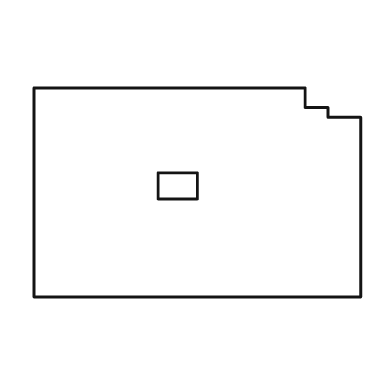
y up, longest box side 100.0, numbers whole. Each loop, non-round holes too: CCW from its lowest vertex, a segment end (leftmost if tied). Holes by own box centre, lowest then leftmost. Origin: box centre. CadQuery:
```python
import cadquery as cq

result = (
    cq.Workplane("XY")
    .moveTo(-50.0, -32.0)
    .lineTo(50.0, -32.0)
    .lineTo(50.0, 23.0)
    .lineTo(40.0, 23.0)
    .lineTo(40.0, 26.0)
    .lineTo(33.0, 26.0)
    .lineTo(33.0, 32.0)
    .lineTo(-50.0, 32.0)
    .close()
    .moveTo(-12.0, -2.0)
    .lineTo(0.0, -2.0)
    .lineTo(0.0, 6.0)
    .lineTo(-12.0, 6.0)
    .close()
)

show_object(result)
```